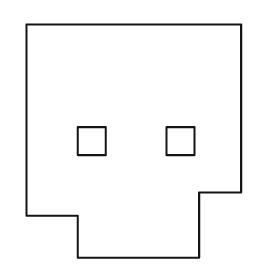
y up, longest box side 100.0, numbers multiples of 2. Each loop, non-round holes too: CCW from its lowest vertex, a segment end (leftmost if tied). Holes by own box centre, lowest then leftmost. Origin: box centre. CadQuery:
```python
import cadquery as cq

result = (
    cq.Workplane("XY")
    .moveTo(-24.0, -50.0)
    .lineTo(28.0, -50.0)
    .lineTo(28.0, -22.0)
    .lineTo(46.0, -22.0)
    .lineTo(46.0, 50.0)
    .lineTo(-46.0, 50.0)
    .lineTo(-46.0, -32.0)
    .lineTo(-24.0, -32.0)
    .close()
    .moveTo(-24.0, -6.0)
    .lineTo(-12.0, -6.0)
    .lineTo(-12.0, 6.0)
    .lineTo(-24.0, 6.0)
    .close()
    .moveTo(14.0, -6.0)
    .lineTo(26.0, -6.0)
    .lineTo(26.0, 6.0)
    .lineTo(14.0, 6.0)
    .close()
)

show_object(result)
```